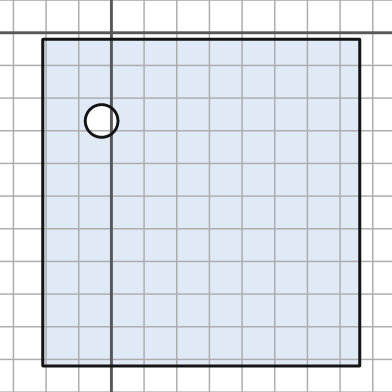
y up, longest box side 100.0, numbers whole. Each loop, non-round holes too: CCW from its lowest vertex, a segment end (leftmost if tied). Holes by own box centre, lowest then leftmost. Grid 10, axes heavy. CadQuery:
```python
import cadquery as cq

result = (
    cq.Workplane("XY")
    .moveTo(-21.0, -102.0)
    .lineTo(76.0, -102.0)
    .lineTo(76.0, -2.0)
    .lineTo(-21.0, -2.0)
    .close()
    .moveTo(-3.0, -27.0)
    .circle(5.0)
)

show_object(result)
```